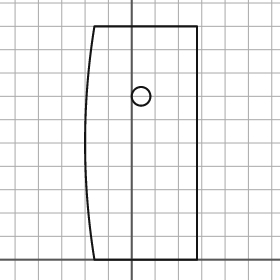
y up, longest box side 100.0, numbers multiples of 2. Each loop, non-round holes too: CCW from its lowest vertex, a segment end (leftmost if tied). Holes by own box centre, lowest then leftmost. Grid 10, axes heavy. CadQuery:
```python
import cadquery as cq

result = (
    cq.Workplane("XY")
    .moveTo(-16.0, 0.0)
    .lineTo(28.0, 0.0)
    .lineTo(28.0, 100.0)
    .lineTo(-16.0, 100.0)
    .threePointArc((-20.0, 50.0), (-16.0, 0.0))
    .close()
    .moveTo(4.0, 70.0)
    .circle(4.0)
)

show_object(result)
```